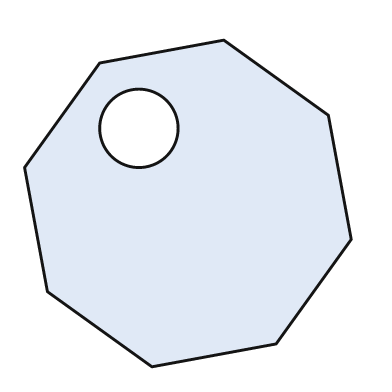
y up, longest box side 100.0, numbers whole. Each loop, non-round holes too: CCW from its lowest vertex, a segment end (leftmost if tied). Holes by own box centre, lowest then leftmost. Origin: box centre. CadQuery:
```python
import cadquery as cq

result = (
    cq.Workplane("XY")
    .moveTo(-11.0, -50.0)
    .lineTo(27.0, -43.0)
    .lineTo(50.0, -11.0)
    .lineTo(43.0, 27.0)
    .lineTo(11.0, 50.0)
    .lineTo(-27.0, 43.0)
    .lineTo(-50.0, 11.0)
    .lineTo(-43.0, -27.0)
    .close()
    .moveTo(-15.0, 23.0)
    .circle(12.0)
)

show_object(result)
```